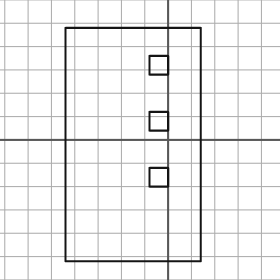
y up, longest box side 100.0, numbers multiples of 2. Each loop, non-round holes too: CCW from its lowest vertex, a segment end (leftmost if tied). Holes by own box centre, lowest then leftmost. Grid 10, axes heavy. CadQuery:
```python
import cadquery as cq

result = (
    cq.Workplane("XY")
    .moveTo(-44.0, -52.0)
    .lineTo(14.0, -52.0)
    .lineTo(14.0, 48.0)
    .lineTo(-44.0, 48.0)
    .close()
    .moveTo(-8.0, -20.0)
    .lineTo(0.0, -20.0)
    .lineTo(0.0, -12.0)
    .lineTo(-8.0, -12.0)
    .close()
    .moveTo(-8.0, 4.0)
    .lineTo(0.0, 4.0)
    .lineTo(0.0, 12.0)
    .lineTo(-8.0, 12.0)
    .close()
    .moveTo(-8.0, 28.0)
    .lineTo(0.0, 28.0)
    .lineTo(0.0, 36.0)
    .lineTo(-8.0, 36.0)
    .close()
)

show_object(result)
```